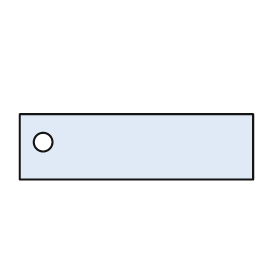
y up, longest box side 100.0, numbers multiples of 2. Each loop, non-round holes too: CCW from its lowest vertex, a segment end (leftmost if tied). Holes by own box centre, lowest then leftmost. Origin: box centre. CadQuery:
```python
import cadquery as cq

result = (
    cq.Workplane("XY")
    .moveTo(-50.0, -14.0)
    .lineTo(50.0, -14.0)
    .lineTo(50.0, 14.0)
    .lineTo(-50.0, 14.0)
    .close()
    .moveTo(-40.0, 2.0)
    .circle(4.0)
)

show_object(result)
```